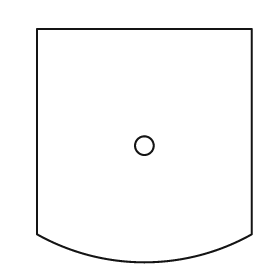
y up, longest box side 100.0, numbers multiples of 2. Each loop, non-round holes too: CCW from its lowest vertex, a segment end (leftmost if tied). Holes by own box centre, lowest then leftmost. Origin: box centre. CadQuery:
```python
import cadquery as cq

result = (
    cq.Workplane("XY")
    .moveTo(-46.0, -38.0)
    .threePointArc((0.0, -50.0), (46.0, -38.0))
    .lineTo(46.0, 50.0)
    .lineTo(-46.0, 50.0)
    .close()
    .moveTo(0.0, 0.0)
    .circle(4.0)
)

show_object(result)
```